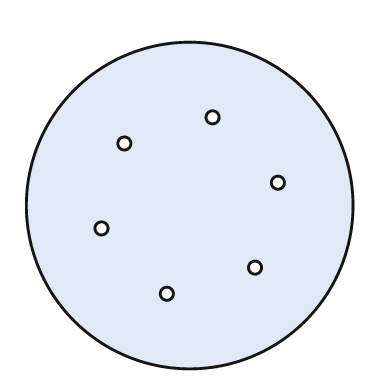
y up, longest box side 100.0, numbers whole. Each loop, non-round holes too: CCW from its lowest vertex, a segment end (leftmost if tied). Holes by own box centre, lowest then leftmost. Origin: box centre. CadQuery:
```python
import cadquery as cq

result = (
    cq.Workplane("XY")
    .moveTo(0.0, 0.0)
    .circle(50.0)
    .moveTo(-7.0, -27.0)
    .circle(2.0)
    .moveTo(20.0, -19.0)
    .circle(2.0)
    .moveTo(-27.0, -7.0)
    .circle(2.0)
    .moveTo(27.0, 7.0)
    .circle(2.0)
    .moveTo(-20.0, 19.0)
    .circle(2.0)
    .moveTo(7.0, 27.0)
    .circle(2.0)
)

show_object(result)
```